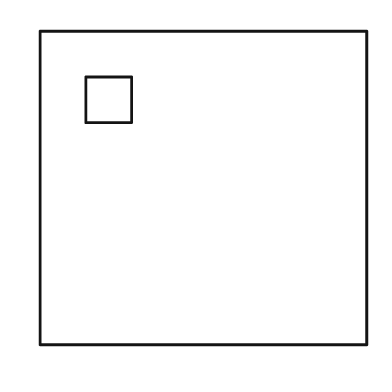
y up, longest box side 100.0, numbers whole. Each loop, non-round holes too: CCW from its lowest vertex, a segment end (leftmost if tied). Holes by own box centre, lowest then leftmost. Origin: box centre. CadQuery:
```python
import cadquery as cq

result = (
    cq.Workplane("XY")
    .moveTo(-50.0, -48.0)
    .lineTo(50.0, -48.0)
    .lineTo(50.0, 48.0)
    .lineTo(-50.0, 48.0)
    .close()
    .moveTo(-36.0, 20.0)
    .lineTo(-22.0, 20.0)
    .lineTo(-22.0, 34.0)
    .lineTo(-36.0, 34.0)
    .close()
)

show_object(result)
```